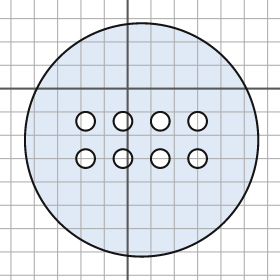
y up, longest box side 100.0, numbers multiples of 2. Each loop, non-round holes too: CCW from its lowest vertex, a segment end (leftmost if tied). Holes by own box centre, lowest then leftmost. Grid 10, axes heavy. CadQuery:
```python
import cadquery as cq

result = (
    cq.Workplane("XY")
    .moveTo(6.0, -22.0)
    .circle(50.0)
    .moveTo(-18.0, -30.0)
    .circle(4.0)
    .moveTo(-2.0, -30.0)
    .circle(4.0)
    .moveTo(14.0, -30.0)
    .circle(4.0)
    .moveTo(30.0, -30.0)
    .circle(4.0)
    .moveTo(-18.0, -14.0)
    .circle(4.0)
    .moveTo(-2.0, -14.0)
    .circle(4.0)
    .moveTo(14.0, -14.0)
    .circle(4.0)
    .moveTo(30.0, -14.0)
    .circle(4.0)
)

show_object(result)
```